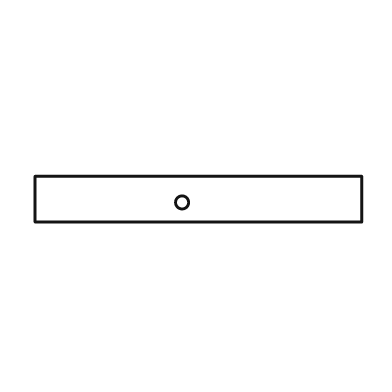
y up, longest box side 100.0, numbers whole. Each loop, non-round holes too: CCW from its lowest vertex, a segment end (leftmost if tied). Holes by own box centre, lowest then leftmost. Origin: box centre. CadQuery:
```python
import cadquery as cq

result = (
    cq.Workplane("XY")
    .moveTo(-50.0, -7.0)
    .lineTo(50.0, -7.0)
    .lineTo(50.0, 7.0)
    .lineTo(-50.0, 7.0)
    .close()
    .moveTo(-5.0, -1.0)
    .circle(2.0)
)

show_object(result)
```